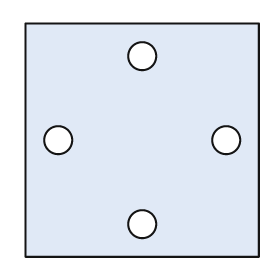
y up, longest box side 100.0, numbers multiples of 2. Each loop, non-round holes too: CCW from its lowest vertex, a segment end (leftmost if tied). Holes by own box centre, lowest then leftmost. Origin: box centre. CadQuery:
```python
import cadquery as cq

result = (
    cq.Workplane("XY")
    .moveTo(-50.0, -50.0)
    .lineTo(50.0, -50.0)
    .lineTo(50.0, 50.0)
    .lineTo(-50.0, 50.0)
    .close()
    .moveTo(0.0, -36.0)
    .circle(6.0)
    .moveTo(-36.0, 0.0)
    .circle(6.0)
    .moveTo(36.0, 0.0)
    .circle(6.0)
    .moveTo(0.0, 36.0)
    .circle(6.0)
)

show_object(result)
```